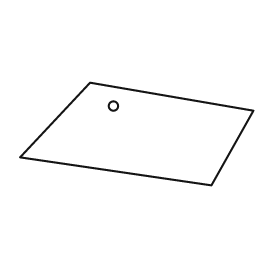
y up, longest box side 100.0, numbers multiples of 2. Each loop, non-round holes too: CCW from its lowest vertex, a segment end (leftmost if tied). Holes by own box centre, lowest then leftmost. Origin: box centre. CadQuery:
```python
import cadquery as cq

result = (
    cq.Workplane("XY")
    .moveTo(32.0, -22.0)
    .lineTo(50.0, 10.0)
    .lineTo(-20.0, 22.0)
    .lineTo(-50.0, -10.0)
    .close()
    .moveTo(-10.0, 12.0)
    .circle(2.0)
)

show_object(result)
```